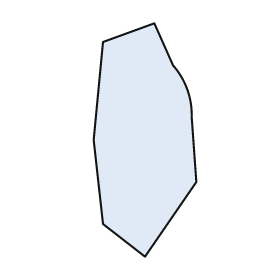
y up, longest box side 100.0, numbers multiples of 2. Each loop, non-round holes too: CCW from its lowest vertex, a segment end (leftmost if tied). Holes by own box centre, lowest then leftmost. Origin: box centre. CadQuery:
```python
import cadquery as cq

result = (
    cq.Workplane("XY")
    .moveTo(0.0, -50.0)
    .lineTo(22.0, -18.0)
    .lineTo(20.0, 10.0)
    .threePointArc((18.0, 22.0), (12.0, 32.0))
    .lineTo(4.0, 50.0)
    .lineTo(-18.0, 42.0)
    .lineTo(-22.0, 0.0)
    .lineTo(-18.0, -36.0)
    .close()
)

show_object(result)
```